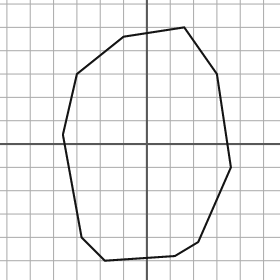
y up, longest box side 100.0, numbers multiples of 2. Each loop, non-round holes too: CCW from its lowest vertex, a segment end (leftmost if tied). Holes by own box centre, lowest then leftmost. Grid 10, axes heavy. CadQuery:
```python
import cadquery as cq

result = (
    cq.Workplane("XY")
    .moveTo(-18.0, -50.0)
    .lineTo(12.0, -48.0)
    .lineTo(22.0, -42.0)
    .lineTo(36.0, -10.0)
    .lineTo(30.0, 30.0)
    .lineTo(16.0, 50.0)
    .lineTo(-10.0, 46.0)
    .lineTo(-30.0, 30.0)
    .lineTo(-36.0, 4.0)
    .lineTo(-28.0, -40.0)
    .close()
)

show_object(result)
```